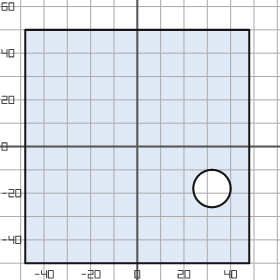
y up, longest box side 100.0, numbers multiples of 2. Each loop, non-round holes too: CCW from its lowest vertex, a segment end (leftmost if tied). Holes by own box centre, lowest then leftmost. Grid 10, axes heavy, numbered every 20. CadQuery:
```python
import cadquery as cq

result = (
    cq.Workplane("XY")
    .moveTo(-48.0, -50.0)
    .lineTo(48.0, -50.0)
    .lineTo(48.0, 50.0)
    .lineTo(-48.0, 50.0)
    .close()
    .moveTo(32.0, -18.0)
    .circle(8.0)
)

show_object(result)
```